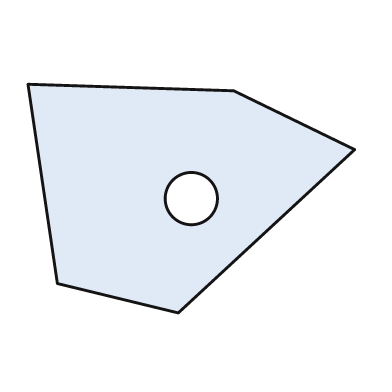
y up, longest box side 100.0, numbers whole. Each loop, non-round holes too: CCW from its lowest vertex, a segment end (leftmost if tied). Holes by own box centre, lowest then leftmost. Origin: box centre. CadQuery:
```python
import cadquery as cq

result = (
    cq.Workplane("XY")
    .moveTo(-4.0, -35.0)
    .lineTo(50.0, 15.0)
    .lineTo(13.0, 33.0)
    .lineTo(-50.0, 35.0)
    .lineTo(-41.0, -26.0)
    .close()
    .moveTo(0.0, 0.0)
    .circle(8.0)
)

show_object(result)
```